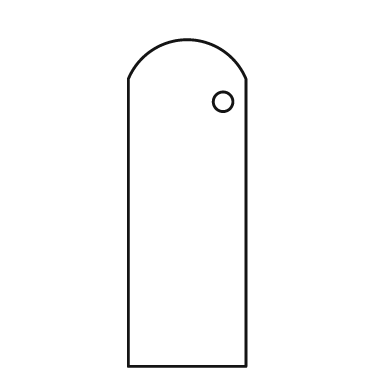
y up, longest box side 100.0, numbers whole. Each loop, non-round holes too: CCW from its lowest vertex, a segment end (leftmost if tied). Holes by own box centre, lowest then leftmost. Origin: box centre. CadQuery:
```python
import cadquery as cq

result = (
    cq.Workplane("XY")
    .moveTo(-18.0, -50.0)
    .lineTo(18.0, -50.0)
    .lineTo(18.0, 38.0)
    .threePointArc((0.0, 50.0), (-18.0, 38.0))
    .close()
    .moveTo(11.0, 31.0)
    .circle(3.0)
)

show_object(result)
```